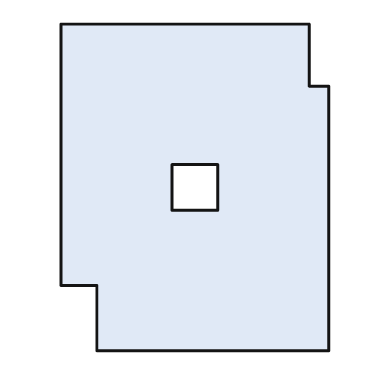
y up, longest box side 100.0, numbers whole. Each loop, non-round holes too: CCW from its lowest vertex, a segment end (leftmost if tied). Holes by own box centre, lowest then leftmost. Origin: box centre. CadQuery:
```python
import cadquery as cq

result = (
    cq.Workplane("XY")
    .moveTo(-30.0, -50.0)
    .lineTo(41.0, -50.0)
    .lineTo(41.0, 31.0)
    .lineTo(35.0, 31.0)
    .lineTo(35.0, 50.0)
    .lineTo(-41.0, 50.0)
    .lineTo(-41.0, -30.0)
    .lineTo(-30.0, -30.0)
    .close()
    .moveTo(-7.0, -7.0)
    .lineTo(7.0, -7.0)
    .lineTo(7.0, 7.0)
    .lineTo(-7.0, 7.0)
    .close()
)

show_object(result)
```